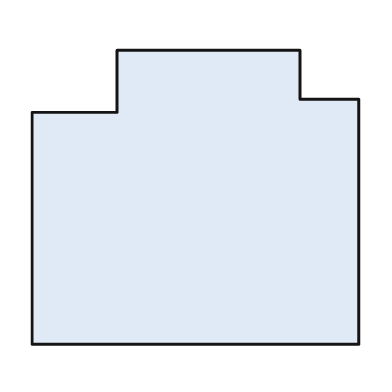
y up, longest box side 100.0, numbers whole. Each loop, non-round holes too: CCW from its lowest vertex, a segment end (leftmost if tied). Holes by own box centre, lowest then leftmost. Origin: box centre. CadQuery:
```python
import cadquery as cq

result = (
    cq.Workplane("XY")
    .moveTo(-50.0, -45.0)
    .lineTo(50.0, -45.0)
    .lineTo(50.0, 30.0)
    .lineTo(32.0, 30.0)
    .lineTo(32.0, 45.0)
    .lineTo(-24.0, 45.0)
    .lineTo(-24.0, 26.0)
    .lineTo(-50.0, 26.0)
    .close()
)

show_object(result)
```